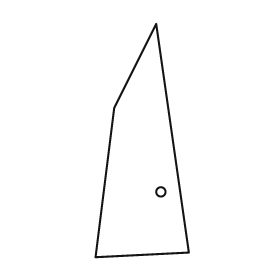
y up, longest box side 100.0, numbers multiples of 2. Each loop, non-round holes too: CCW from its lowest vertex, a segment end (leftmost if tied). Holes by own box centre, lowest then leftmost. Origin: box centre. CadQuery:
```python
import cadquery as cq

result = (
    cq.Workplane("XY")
    .moveTo(-20.0, -50.0)
    .lineTo(20.0, -48.0)
    .lineTo(6.0, 50.0)
    .lineTo(-12.0, 14.0)
    .close()
    .moveTo(8.0, -22.0)
    .circle(2.0)
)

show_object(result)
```